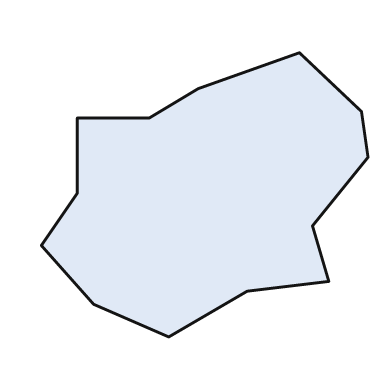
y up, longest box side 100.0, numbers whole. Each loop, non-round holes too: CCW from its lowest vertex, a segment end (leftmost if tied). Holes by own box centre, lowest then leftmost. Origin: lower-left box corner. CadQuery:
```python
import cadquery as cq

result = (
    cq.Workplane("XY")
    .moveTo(39.0, 0.0)
    .lineTo(63.0, 14.0)
    .lineTo(88.0, 17.0)
    .lineTo(83.0, 34.0)
    .lineTo(100.0, 55.0)
    .lineTo(98.0, 69.0)
    .lineTo(79.0, 87.0)
    .lineTo(48.0, 76.0)
    .lineTo(33.0, 67.0)
    .lineTo(11.0, 67.0)
    .lineTo(11.0, 44.0)
    .lineTo(0.0, 28.0)
    .lineTo(16.0, 10.0)
    .close()
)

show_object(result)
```